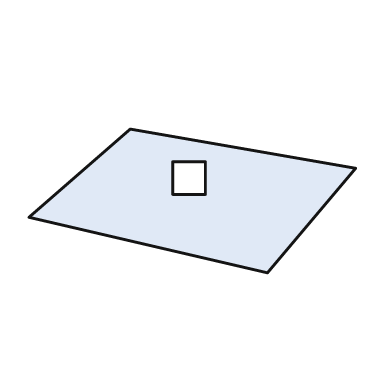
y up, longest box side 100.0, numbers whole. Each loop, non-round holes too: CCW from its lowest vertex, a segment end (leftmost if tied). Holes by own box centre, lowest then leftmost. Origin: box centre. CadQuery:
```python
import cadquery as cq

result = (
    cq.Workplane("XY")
    .moveTo(23.0, -22.0)
    .lineTo(50.0, 10.0)
    .lineTo(-19.0, 22.0)
    .lineTo(-50.0, -5.0)
    .close()
    .moveTo(-6.0, 2.0)
    .lineTo(4.0, 2.0)
    .lineTo(4.0, 12.0)
    .lineTo(-6.0, 12.0)
    .close()
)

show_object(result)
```